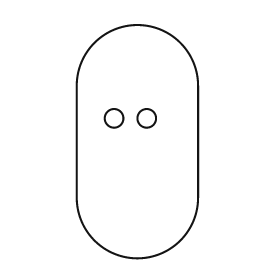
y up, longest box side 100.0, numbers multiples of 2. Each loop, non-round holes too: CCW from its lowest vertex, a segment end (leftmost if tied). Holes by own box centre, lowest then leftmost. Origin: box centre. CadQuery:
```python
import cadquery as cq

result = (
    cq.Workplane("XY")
    .moveTo(-26.0, -24.0)
    .threePointArc((0.0, -50.0), (26.0, -24.0))
    .lineTo(26.0, 24.0)
    .threePointArc((0.0, 50.0), (-26.0, 24.0))
    .close()
    .moveTo(-10.0, 10.0)
    .circle(4.0)
    .moveTo(4.0, 10.0)
    .circle(4.0)
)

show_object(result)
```